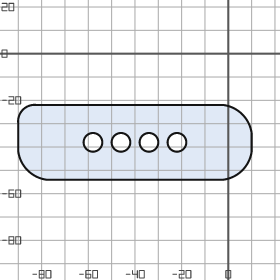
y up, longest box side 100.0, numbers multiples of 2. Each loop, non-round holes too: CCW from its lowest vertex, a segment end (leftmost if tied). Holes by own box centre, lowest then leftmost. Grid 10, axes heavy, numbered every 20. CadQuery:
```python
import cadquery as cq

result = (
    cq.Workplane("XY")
    .moveTo(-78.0, -54.0)
    .lineTo(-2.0, -54.0)
    .threePointArc((6.0, -50.0), (10.0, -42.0))
    .lineTo(10.0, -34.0)
    .threePointArc((6.0, -26.0), (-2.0, -22.0))
    .lineTo(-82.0, -22.0)
    .threePointArc((-88.0, -24.0), (-90.0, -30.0))
    .lineTo(-90.0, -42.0)
    .threePointArc((-86.0, -50.0), (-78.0, -54.0))
    .close()
    .moveTo(-58.0, -38.0)
    .circle(4.0)
    .moveTo(-46.0, -38.0)
    .circle(4.0)
    .moveTo(-34.0, -38.0)
    .circle(4.0)
    .moveTo(-22.0, -38.0)
    .circle(4.0)
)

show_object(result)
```